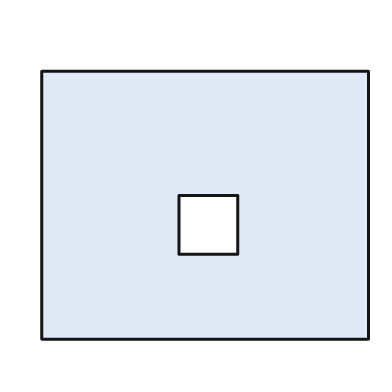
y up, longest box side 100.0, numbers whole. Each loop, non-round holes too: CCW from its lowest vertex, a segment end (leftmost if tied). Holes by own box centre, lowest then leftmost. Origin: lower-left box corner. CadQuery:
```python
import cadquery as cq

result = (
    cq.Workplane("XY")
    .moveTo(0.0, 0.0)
    .lineTo(100.0, 0.0)
    .lineTo(100.0, 82.0)
    .lineTo(0.0, 82.0)
    .close()
    .moveTo(42.0, 26.0)
    .lineTo(60.0, 26.0)
    .lineTo(60.0, 44.0)
    .lineTo(42.0, 44.0)
    .close()
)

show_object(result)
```